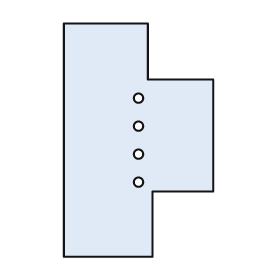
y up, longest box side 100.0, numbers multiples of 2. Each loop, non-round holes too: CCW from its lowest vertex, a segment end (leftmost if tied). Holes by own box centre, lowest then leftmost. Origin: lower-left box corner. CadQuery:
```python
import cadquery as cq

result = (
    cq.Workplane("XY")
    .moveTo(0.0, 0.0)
    .lineTo(38.0, 0.0)
    .lineTo(38.0, 28.0)
    .lineTo(64.0, 28.0)
    .lineTo(64.0, 76.0)
    .lineTo(36.0, 76.0)
    .lineTo(36.0, 100.0)
    .lineTo(0.0, 100.0)
    .close()
    .moveTo(32.0, 32.0)
    .circle(2.0)
    .moveTo(32.0, 44.0)
    .circle(2.0)
    .moveTo(32.0, 56.0)
    .circle(2.0)
    .moveTo(32.0, 68.0)
    .circle(2.0)
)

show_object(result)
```